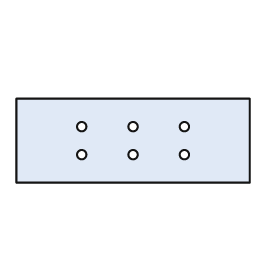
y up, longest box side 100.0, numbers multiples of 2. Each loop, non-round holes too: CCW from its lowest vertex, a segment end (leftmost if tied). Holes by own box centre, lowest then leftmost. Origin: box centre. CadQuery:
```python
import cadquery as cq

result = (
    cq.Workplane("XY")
    .moveTo(-50.0, -18.0)
    .lineTo(50.0, -18.0)
    .lineTo(50.0, 18.0)
    .lineTo(-50.0, 18.0)
    .close()
    .moveTo(-22.0, -6.0)
    .circle(2.0)
    .moveTo(0.0, -6.0)
    .circle(2.0)
    .moveTo(22.0, -6.0)
    .circle(2.0)
    .moveTo(-22.0, 6.0)
    .circle(2.0)
    .moveTo(0.0, 6.0)
    .circle(2.0)
    .moveTo(22.0, 6.0)
    .circle(2.0)
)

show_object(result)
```